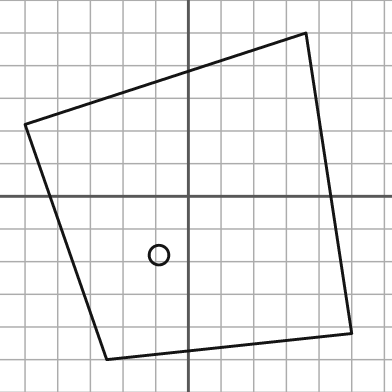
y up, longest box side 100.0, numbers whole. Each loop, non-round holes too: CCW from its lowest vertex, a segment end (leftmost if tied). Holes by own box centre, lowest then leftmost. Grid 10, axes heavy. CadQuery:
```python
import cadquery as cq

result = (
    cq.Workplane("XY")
    .moveTo(-25.0, -50.0)
    .lineTo(50.0, -42.0)
    .lineTo(36.0, 50.0)
    .lineTo(-50.0, 22.0)
    .close()
    .moveTo(-9.0, -18.0)
    .circle(3.0)
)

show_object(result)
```